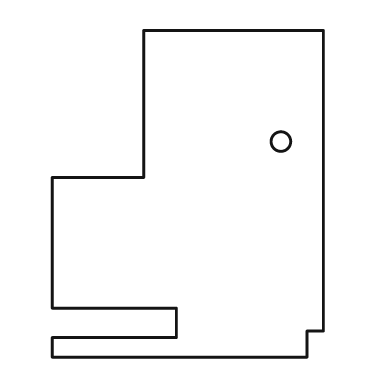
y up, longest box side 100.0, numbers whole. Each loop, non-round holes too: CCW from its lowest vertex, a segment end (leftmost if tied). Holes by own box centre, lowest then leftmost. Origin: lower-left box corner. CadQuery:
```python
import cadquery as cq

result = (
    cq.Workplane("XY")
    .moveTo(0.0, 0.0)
    .lineTo(78.0, 0.0)
    .lineTo(78.0, 8.0)
    .lineTo(83.0, 8.0)
    .lineTo(83.0, 100.0)
    .lineTo(28.0, 100.0)
    .lineTo(28.0, 55.0)
    .lineTo(0.0, 55.0)
    .lineTo(0.0, 15.0)
    .lineTo(38.0, 15.0)
    .lineTo(38.0, 6.0)
    .lineTo(0.0, 6.0)
    .close()
    .moveTo(70.0, 66.0)
    .circle(3.0)
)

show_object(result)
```